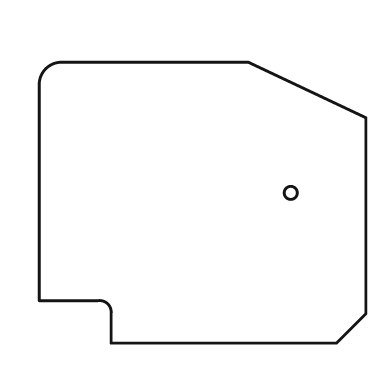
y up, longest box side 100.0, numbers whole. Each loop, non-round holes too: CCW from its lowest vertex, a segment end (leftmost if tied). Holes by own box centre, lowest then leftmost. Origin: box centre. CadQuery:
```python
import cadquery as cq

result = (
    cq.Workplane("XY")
    .moveTo(-28.0, -43.0)
    .lineTo(41.0, -43.0)
    .lineTo(50.0, -34.0)
    .lineTo(50.0, 26.0)
    .lineTo(14.0, 43.0)
    .lineTo(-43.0, 43.0)
    .threePointArc((-48.0, 41.0), (-50.0, 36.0))
    .lineTo(-50.0, -30.0)
    .lineTo(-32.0, -30.0)
    .threePointArc((-29.0, -31.0), (-28.0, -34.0))
    .close()
    .moveTo(27.0, 3.0)
    .circle(2.0)
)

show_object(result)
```